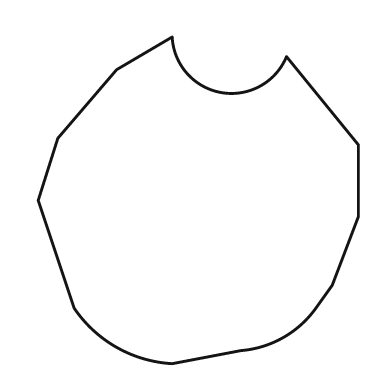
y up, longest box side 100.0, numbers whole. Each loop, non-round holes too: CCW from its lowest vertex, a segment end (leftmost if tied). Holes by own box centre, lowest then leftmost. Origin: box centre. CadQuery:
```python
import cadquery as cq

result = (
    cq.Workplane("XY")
    .moveTo(-8.0, -50.0)
    .lineTo(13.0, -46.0)
    .threePointArc((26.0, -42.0), (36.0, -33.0))
    .lineTo(41.0, -26.0)
    .lineTo(49.0, -5.0)
    .lineTo(49.0, 17.0)
    .lineTo(27.0, 44.0)
    .threePointArc((7.0, 33.0), (-8.0, 50.0))
    .lineTo(-25.0, 40.0)
    .lineTo(-43.0, 19.0)
    .lineTo(-49.0, 0.0)
    .lineTo(-38.0, -33.0)
    .threePointArc((-25.0, -45.0), (-8.0, -50.0))
    .close()
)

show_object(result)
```